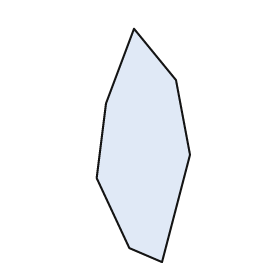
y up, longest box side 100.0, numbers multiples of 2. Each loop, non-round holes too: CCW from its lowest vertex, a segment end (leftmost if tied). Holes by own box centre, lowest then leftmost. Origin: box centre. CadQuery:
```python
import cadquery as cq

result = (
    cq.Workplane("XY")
    .moveTo(8.0, -50.0)
    .lineTo(20.0, -4.0)
    .lineTo(14.0, 28.0)
    .lineTo(-4.0, 50.0)
    .lineTo(-16.0, 18.0)
    .lineTo(-20.0, -14.0)
    .lineTo(-6.0, -44.0)
    .close()
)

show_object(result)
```